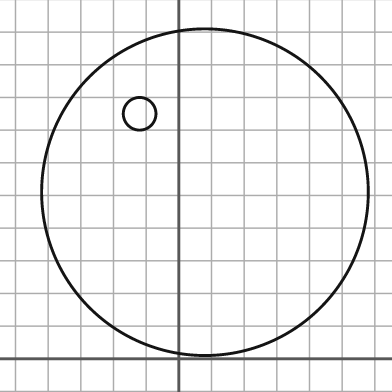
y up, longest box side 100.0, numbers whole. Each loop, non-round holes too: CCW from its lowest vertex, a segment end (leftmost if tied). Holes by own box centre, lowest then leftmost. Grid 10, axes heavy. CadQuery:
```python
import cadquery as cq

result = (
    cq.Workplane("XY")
    .moveTo(8.0, 51.0)
    .circle(50.0)
    .moveTo(-12.0, 75.0)
    .circle(5.0)
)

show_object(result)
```